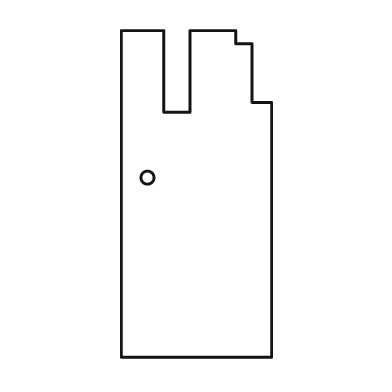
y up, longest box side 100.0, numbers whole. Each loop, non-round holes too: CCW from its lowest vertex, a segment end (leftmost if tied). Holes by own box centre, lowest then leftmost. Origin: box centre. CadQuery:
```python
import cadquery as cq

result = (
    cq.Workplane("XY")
    .moveTo(-23.0, -50.0)
    .lineTo(23.0, -50.0)
    .lineTo(23.0, 28.0)
    .lineTo(17.0, 28.0)
    .lineTo(17.0, 46.0)
    .lineTo(12.0, 46.0)
    .lineTo(12.0, 50.0)
    .lineTo(-2.0, 50.0)
    .lineTo(-2.0, 25.0)
    .lineTo(-10.0, 25.0)
    .lineTo(-10.0, 50.0)
    .lineTo(-23.0, 50.0)
    .close()
    .moveTo(-15.0, 5.0)
    .circle(2.0)
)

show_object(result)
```